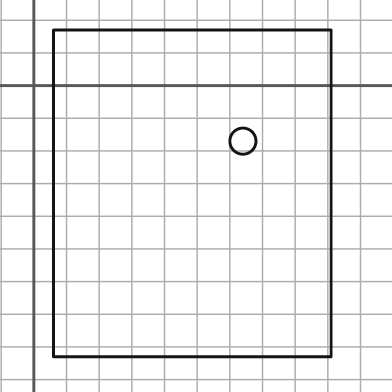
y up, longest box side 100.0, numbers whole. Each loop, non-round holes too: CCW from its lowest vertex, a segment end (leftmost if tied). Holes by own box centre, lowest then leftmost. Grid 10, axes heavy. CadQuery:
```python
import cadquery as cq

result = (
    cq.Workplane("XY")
    .moveTo(6.0, -83.0)
    .lineTo(91.0, -83.0)
    .lineTo(91.0, 17.0)
    .lineTo(6.0, 17.0)
    .close()
    .moveTo(64.0, -17.0)
    .circle(4.0)
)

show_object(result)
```